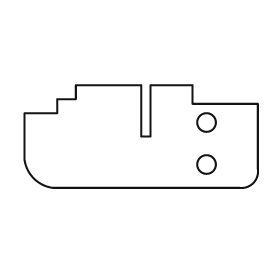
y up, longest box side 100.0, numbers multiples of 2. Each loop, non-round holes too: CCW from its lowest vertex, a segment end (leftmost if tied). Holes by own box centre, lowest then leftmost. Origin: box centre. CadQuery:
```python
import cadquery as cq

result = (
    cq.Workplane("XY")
    .moveTo(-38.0, -22.0)
    .lineTo(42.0, -22.0)
    .threePointArc((48.0, -20.0), (50.0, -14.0))
    .lineTo(50.0, 14.0)
    .lineTo(22.0, 14.0)
    .lineTo(22.0, 22.0)
    .lineTo(4.0, 22.0)
    .lineTo(4.0, 0.0)
    .lineTo(0.0, 0.0)
    .lineTo(0.0, 22.0)
    .lineTo(-28.0, 22.0)
    .lineTo(-28.0, 16.0)
    .lineTo(-36.0, 16.0)
    .lineTo(-36.0, 10.0)
    .lineTo(-50.0, 10.0)
    .lineTo(-50.0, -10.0)
    .threePointArc((-46.0, -18.0), (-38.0, -22.0))
    .close()
    .moveTo(28.0, -12.0)
    .circle(4.0)
    .moveTo(28.0, 6.0)
    .circle(4.0)
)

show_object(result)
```